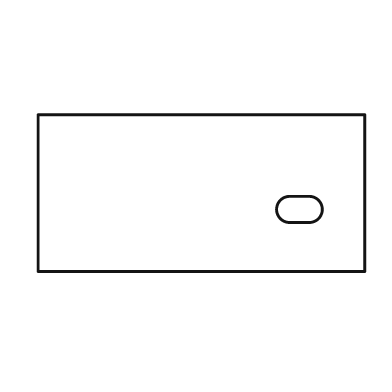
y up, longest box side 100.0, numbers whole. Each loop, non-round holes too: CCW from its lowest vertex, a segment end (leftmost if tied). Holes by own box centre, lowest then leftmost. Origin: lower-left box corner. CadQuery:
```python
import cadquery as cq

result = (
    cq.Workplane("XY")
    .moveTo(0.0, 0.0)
    .lineTo(100.0, 0.0)
    .lineTo(100.0, 48.0)
    .lineTo(0.0, 48.0)
    .close()
    .moveTo(77.0, 15.0)
    .lineTo(83.0, 15.0)
    .threePointArc((87.0, 19.0), (83.0, 23.0))
    .lineTo(77.0, 23.0)
    .threePointArc((73.0, 19.0), (77.0, 15.0))
    .close()
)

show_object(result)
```